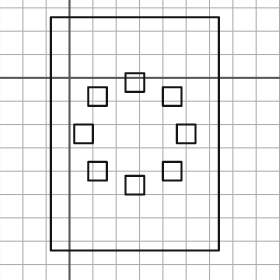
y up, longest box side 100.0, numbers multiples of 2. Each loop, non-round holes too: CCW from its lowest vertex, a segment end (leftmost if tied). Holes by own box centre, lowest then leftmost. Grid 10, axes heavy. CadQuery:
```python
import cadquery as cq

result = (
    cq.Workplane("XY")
    .moveTo(-8.0, -74.0)
    .lineTo(64.0, -74.0)
    .lineTo(64.0, 26.0)
    .lineTo(-8.0, 26.0)
    .close()
    .moveTo(24.0, -50.0)
    .lineTo(32.0, -50.0)
    .lineTo(32.0, -42.0)
    .lineTo(24.0, -42.0)
    .close()
    .moveTo(8.0, -44.0)
    .lineTo(16.0, -44.0)
    .lineTo(16.0, -36.0)
    .lineTo(8.0, -36.0)
    .close()
    .moveTo(40.0, -44.0)
    .lineTo(48.0, -44.0)
    .lineTo(48.0, -36.0)
    .lineTo(40.0, -36.0)
    .close()
    .moveTo(2.0, -28.0)
    .lineTo(10.0, -28.0)
    .lineTo(10.0, -20.0)
    .lineTo(2.0, -20.0)
    .close()
    .moveTo(46.0, -28.0)
    .lineTo(54.0, -28.0)
    .lineTo(54.0, -20.0)
    .lineTo(46.0, -20.0)
    .close()
    .moveTo(8.0, -12.0)
    .lineTo(16.0, -12.0)
    .lineTo(16.0, -4.0)
    .lineTo(8.0, -4.0)
    .close()
    .moveTo(40.0, -12.0)
    .lineTo(48.0, -12.0)
    .lineTo(48.0, -4.0)
    .lineTo(40.0, -4.0)
    .close()
    .moveTo(24.0, -6.0)
    .lineTo(32.0, -6.0)
    .lineTo(32.0, 2.0)
    .lineTo(24.0, 2.0)
    .close()
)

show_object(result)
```